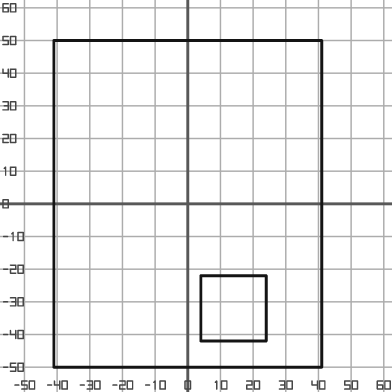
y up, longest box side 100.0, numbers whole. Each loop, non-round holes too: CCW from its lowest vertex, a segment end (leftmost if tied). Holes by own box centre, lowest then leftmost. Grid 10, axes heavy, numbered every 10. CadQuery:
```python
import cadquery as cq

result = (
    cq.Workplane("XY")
    .moveTo(-41.0, -50.0)
    .lineTo(41.0, -50.0)
    .lineTo(41.0, 50.0)
    .lineTo(-41.0, 50.0)
    .close()
    .moveTo(4.0, -42.0)
    .lineTo(24.0, -42.0)
    .lineTo(24.0, -22.0)
    .lineTo(4.0, -22.0)
    .close()
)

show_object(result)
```